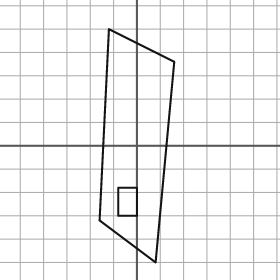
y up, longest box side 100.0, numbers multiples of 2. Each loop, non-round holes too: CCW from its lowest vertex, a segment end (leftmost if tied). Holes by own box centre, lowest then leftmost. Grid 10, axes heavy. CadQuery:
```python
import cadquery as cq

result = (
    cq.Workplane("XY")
    .moveTo(8.0, -50.0)
    .lineTo(16.0, 36.0)
    .lineTo(-12.0, 50.0)
    .lineTo(-16.0, -32.0)
    .close()
    .moveTo(-8.0, -30.0)
    .lineTo(0.0, -30.0)
    .lineTo(0.0, -18.0)
    .lineTo(-8.0, -18.0)
    .close()
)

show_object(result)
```